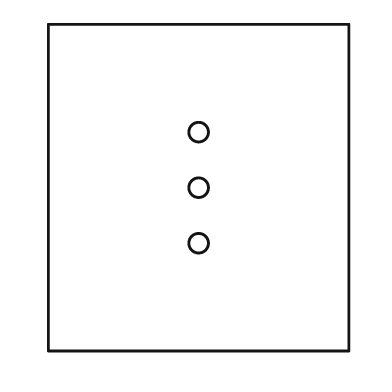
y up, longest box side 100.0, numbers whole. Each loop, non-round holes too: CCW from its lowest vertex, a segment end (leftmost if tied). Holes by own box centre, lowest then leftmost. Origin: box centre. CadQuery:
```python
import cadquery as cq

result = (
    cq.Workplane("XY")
    .moveTo(-46.0, -50.0)
    .lineTo(46.0, -50.0)
    .lineTo(46.0, 50.0)
    .lineTo(-46.0, 50.0)
    .close()
    .moveTo(0.0, -17.0)
    .circle(3.0)
    .moveTo(0.0, 0.0)
    .circle(3.0)
    .moveTo(0.0, 17.0)
    .circle(3.0)
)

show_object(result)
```